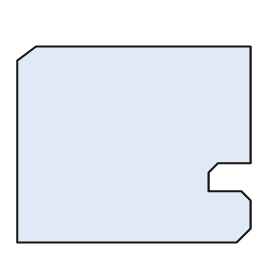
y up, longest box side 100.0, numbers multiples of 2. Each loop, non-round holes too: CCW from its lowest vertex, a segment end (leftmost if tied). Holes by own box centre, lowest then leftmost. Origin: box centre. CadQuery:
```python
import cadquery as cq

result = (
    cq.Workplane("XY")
    .moveTo(-50.0, -42.0)
    .lineTo(44.0, -42.0)
    .lineTo(50.0, -36.0)
    .lineTo(50.0, -24.0)
    .lineTo(46.0, -20.0)
    .lineTo(32.0, -20.0)
    .lineTo(32.0, -12.0)
    .lineTo(36.0, -8.0)
    .lineTo(50.0, -8.0)
    .lineTo(50.0, 42.0)
    .lineTo(-42.0, 42.0)
    .lineTo(-50.0, 36.0)
    .close()
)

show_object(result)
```